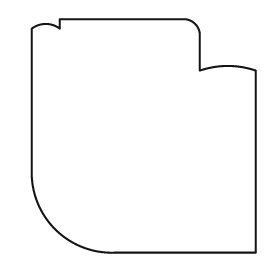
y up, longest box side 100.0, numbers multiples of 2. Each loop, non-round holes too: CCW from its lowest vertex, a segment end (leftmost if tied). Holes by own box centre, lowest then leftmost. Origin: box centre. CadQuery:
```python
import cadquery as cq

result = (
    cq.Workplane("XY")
    .moveTo(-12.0, -50.0)
    .lineTo(48.0, -50.0)
    .lineTo(48.0, 28.0)
    .threePointArc((36.0, 30.0), (24.0, 28.0))
    .lineTo(24.0, 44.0)
    .threePointArc((22.0, 48.0), (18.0, 50.0))
    .lineTo(-36.0, 50.0)
    .lineTo(-36.0, 46.0)
    .threePointArc((-42.0, 48.0), (-48.0, 46.0))
    .lineTo(-48.0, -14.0)
    .threePointArc((-38.0, -40.0), (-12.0, -50.0))
    .close()
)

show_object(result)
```